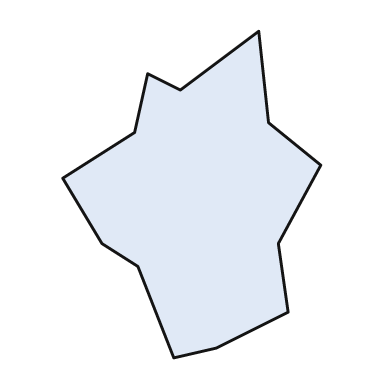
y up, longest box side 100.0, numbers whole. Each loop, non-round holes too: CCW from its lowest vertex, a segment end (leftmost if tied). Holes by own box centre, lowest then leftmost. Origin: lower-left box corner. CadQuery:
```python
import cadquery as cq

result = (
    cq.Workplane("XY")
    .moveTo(34.0, 0.0)
    .lineTo(47.0, 3.0)
    .lineTo(69.0, 14.0)
    .lineTo(66.0, 35.0)
    .lineTo(79.0, 59.0)
    .lineTo(63.0, 72.0)
    .lineTo(60.0, 100.0)
    .lineTo(36.0, 82.0)
    .lineTo(26.0, 87.0)
    .lineTo(22.0, 69.0)
    .lineTo(0.0, 55.0)
    .lineTo(12.0, 35.0)
    .lineTo(23.0, 28.0)
    .close()
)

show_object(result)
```